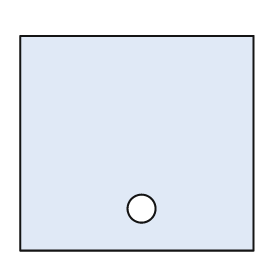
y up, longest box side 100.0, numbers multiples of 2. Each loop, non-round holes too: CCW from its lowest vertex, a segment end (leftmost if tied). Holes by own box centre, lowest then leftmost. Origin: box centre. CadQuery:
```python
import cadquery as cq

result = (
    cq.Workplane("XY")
    .moveTo(-50.0, -46.0)
    .lineTo(50.0, -46.0)
    .lineTo(50.0, 46.0)
    .lineTo(-50.0, 46.0)
    .close()
    .moveTo(2.0, -28.0)
    .circle(6.0)
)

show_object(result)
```